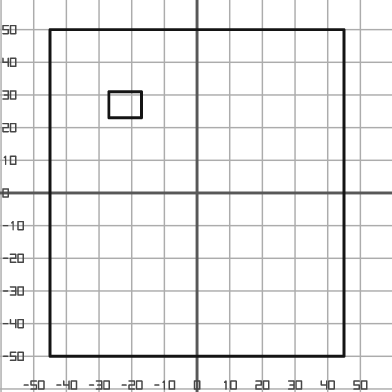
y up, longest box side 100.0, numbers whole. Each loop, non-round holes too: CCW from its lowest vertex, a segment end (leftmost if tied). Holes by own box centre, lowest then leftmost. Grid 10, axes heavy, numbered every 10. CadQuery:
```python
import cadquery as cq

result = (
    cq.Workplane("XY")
    .moveTo(-45.0, -50.0)
    .lineTo(45.0, -50.0)
    .lineTo(45.0, 50.0)
    .lineTo(-45.0, 50.0)
    .close()
    .moveTo(-27.0, 23.0)
    .lineTo(-17.0, 23.0)
    .lineTo(-17.0, 31.0)
    .lineTo(-27.0, 31.0)
    .close()
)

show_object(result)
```